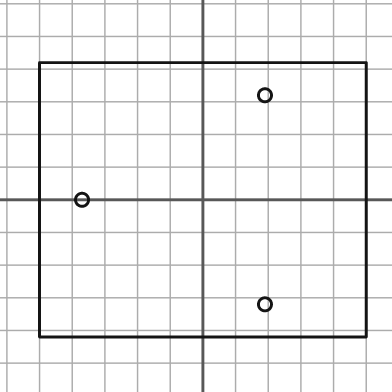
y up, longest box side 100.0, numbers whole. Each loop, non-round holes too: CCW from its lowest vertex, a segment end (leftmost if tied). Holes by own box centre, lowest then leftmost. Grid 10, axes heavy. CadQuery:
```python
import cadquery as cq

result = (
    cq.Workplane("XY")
    .moveTo(-50.0, -42.0)
    .lineTo(50.0, -42.0)
    .lineTo(50.0, 42.0)
    .lineTo(-50.0, 42.0)
    .close()
    .moveTo(19.0, -32.0)
    .circle(2.0)
    .moveTo(-37.0, 0.0)
    .circle(2.0)
    .moveTo(19.0, 32.0)
    .circle(2.0)
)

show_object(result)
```